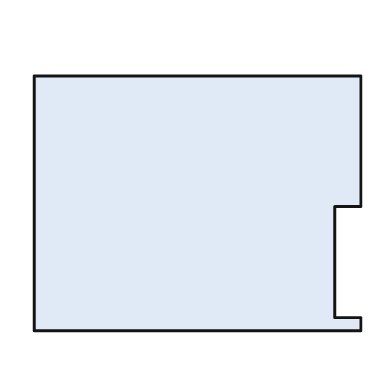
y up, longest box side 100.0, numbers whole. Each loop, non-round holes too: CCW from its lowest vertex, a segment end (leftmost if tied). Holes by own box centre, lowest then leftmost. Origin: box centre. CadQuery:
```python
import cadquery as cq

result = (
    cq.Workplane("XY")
    .moveTo(-50.0, -39.0)
    .lineTo(50.0, -39.0)
    .lineTo(50.0, -35.0)
    .lineTo(42.0, -35.0)
    .lineTo(42.0, -1.0)
    .lineTo(50.0, -1.0)
    .lineTo(50.0, 39.0)
    .lineTo(-50.0, 39.0)
    .close()
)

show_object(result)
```